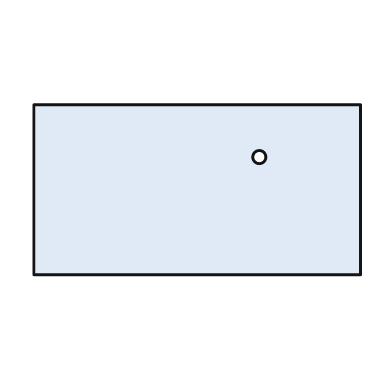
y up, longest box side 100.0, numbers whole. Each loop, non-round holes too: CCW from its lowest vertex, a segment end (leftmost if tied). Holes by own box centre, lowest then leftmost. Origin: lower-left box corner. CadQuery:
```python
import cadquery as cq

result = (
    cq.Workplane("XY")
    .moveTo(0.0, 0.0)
    .lineTo(100.0, 0.0)
    .lineTo(100.0, 52.0)
    .lineTo(0.0, 52.0)
    .close()
    .moveTo(69.0, 36.0)
    .circle(2.0)
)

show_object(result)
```